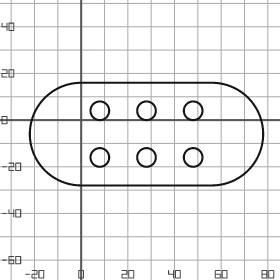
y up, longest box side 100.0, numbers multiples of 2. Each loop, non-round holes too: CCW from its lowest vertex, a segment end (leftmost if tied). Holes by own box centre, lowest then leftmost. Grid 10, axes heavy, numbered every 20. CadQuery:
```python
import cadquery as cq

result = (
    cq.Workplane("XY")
    .moveTo(0.0, -28.0)
    .lineTo(56.0, -28.0)
    .threePointArc((78.0, -6.0), (56.0, 16.0))
    .lineTo(0.0, 16.0)
    .threePointArc((-22.0, -6.0), (0.0, -28.0))
    .close()
    .moveTo(8.0, -16.0)
    .circle(4.0)
    .moveTo(28.0, -16.0)
    .circle(4.0)
    .moveTo(48.0, -16.0)
    .circle(4.0)
    .moveTo(8.0, 4.0)
    .circle(4.0)
    .moveTo(28.0, 4.0)
    .circle(4.0)
    .moveTo(48.0, 4.0)
    .circle(4.0)
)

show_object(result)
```